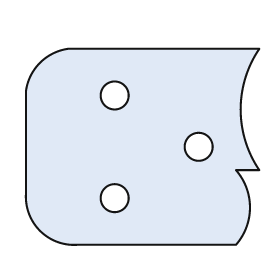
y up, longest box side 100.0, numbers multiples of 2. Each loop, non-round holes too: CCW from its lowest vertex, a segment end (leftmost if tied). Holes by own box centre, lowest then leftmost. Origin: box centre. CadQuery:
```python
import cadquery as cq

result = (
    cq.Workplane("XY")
    .moveTo(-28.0, -42.0)
    .lineTo(40.0, -42.0)
    .threePointArc((46.0, -26.0), (40.0, -10.0))
    .lineTo(50.0, -10.0)
    .threePointArc((42.0, 16.0), (50.0, 42.0))
    .lineTo(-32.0, 42.0)
    .threePointArc((-44.0, 36.0), (-50.0, 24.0))
    .lineTo(-50.0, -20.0)
    .threePointArc((-44.0, -36.0), (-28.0, -42.0))
    .close()
    .moveTo(-12.0, -22.0)
    .circle(6.0)
    .moveTo(24.0, 0.0)
    .circle(6.0)
    .moveTo(-12.0, 22.0)
    .circle(6.0)
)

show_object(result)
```